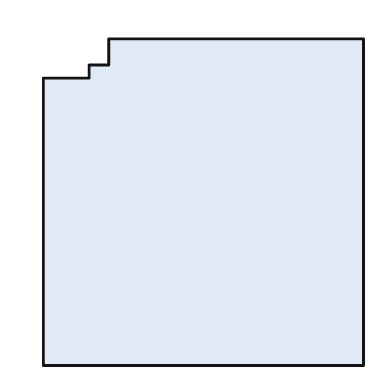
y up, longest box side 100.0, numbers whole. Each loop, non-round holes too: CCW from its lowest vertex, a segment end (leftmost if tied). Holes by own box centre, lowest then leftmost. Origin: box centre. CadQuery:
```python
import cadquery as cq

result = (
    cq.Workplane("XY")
    .moveTo(-49.0, -50.0)
    .lineTo(49.0, -50.0)
    .lineTo(49.0, 50.0)
    .lineTo(-29.0, 50.0)
    .lineTo(-29.0, 42.0)
    .lineTo(-35.0, 42.0)
    .lineTo(-35.0, 38.0)
    .lineTo(-49.0, 38.0)
    .close()
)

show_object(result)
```